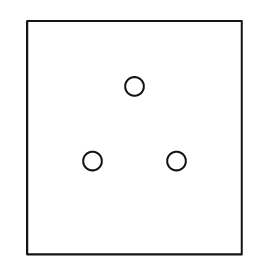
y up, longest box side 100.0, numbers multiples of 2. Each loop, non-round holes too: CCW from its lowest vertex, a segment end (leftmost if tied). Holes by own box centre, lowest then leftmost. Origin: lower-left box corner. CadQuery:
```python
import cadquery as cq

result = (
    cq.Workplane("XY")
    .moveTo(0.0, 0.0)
    .lineTo(92.0, 0.0)
    .lineTo(92.0, 100.0)
    .lineTo(0.0, 100.0)
    .close()
    .moveTo(28.0, 40.0)
    .circle(4.0)
    .moveTo(64.0, 40.0)
    .circle(4.0)
    .moveTo(46.0, 72.0)
    .circle(4.0)
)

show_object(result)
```